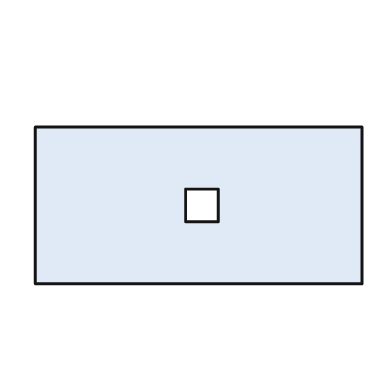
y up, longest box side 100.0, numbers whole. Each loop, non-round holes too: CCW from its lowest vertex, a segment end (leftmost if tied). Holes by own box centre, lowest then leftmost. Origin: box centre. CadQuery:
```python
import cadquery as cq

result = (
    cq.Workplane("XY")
    .moveTo(-50.0, -24.0)
    .lineTo(50.0, -24.0)
    .lineTo(50.0, 24.0)
    .lineTo(-50.0, 24.0)
    .close()
    .moveTo(-4.0, -5.0)
    .lineTo(6.0, -5.0)
    .lineTo(6.0, 5.0)
    .lineTo(-4.0, 5.0)
    .close()
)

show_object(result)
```